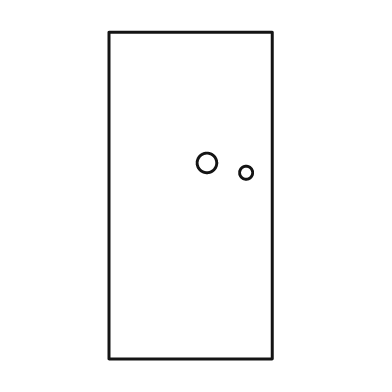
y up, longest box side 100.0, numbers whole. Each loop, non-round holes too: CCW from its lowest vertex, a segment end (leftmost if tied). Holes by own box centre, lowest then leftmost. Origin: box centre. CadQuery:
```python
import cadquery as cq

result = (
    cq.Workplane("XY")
    .moveTo(-25.0, -50.0)
    .lineTo(25.0, -50.0)
    .lineTo(25.0, 50.0)
    .lineTo(-25.0, 50.0)
    .close()
    .moveTo(17.0, 7.0)
    .circle(2.0)
    .moveTo(5.0, 10.0)
    .circle(3.0)
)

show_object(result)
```